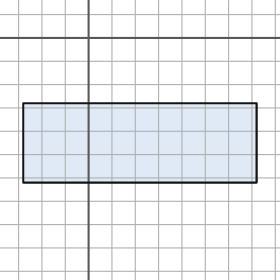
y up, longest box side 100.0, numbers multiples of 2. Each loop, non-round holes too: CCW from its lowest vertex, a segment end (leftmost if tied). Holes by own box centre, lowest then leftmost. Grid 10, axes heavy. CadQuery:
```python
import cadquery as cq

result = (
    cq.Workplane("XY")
    .moveTo(-28.0, -62.0)
    .lineTo(72.0, -62.0)
    .lineTo(72.0, -28.0)
    .lineTo(-28.0, -28.0)
    .close()
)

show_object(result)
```